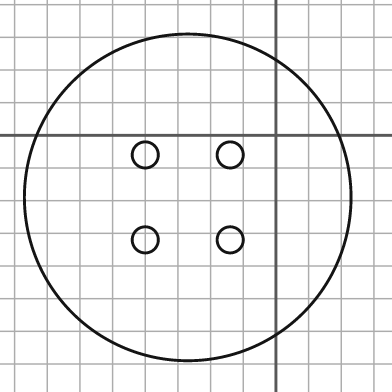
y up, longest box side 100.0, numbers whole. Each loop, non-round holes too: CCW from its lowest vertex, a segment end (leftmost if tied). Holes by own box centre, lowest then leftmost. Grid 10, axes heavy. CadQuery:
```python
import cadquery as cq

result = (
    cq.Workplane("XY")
    .moveTo(-27.0, -19.0)
    .circle(50.0)
    .moveTo(-40.0, -32.0)
    .circle(4.0)
    .moveTo(-14.0, -32.0)
    .circle(4.0)
    .moveTo(-40.0, -6.0)
    .circle(4.0)
    .moveTo(-14.0, -6.0)
    .circle(4.0)
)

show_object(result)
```